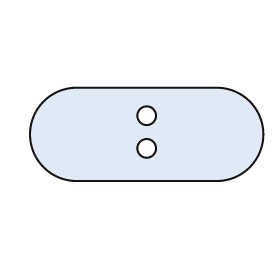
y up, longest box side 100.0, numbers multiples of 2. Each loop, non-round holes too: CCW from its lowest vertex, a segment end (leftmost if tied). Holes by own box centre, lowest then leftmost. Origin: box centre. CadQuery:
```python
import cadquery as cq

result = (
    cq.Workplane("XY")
    .moveTo(-30.0, -20.0)
    .lineTo(30.0, -20.0)
    .threePointArc((50.0, 0.0), (30.0, 20.0))
    .lineTo(-30.0, 20.0)
    .threePointArc((-50.0, 0.0), (-30.0, -20.0))
    .close()
    .moveTo(0.0, -6.0)
    .circle(4.0)
    .moveTo(0.0, 8.0)
    .circle(4.0)
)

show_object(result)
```